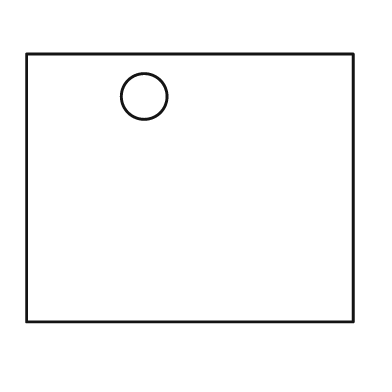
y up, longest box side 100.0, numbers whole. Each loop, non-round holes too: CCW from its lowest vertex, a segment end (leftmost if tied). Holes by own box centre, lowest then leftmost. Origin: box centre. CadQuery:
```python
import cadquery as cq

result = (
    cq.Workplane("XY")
    .moveTo(-50.0, -41.0)
    .lineTo(50.0, -41.0)
    .lineTo(50.0, 41.0)
    .lineTo(-50.0, 41.0)
    .close()
    .moveTo(-14.0, 28.0)
    .circle(7.0)
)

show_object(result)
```